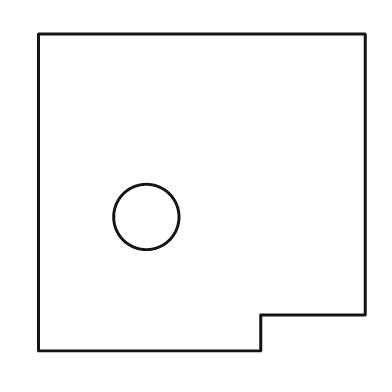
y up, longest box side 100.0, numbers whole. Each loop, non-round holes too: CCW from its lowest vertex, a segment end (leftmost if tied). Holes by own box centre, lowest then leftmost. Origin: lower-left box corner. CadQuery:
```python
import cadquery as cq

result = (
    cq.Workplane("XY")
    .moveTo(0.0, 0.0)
    .lineTo(68.0, 0.0)
    .lineTo(68.0, 11.0)
    .lineTo(100.0, 11.0)
    .lineTo(100.0, 97.0)
    .lineTo(0.0, 97.0)
    .close()
    .moveTo(33.0, 41.0)
    .circle(10.0)
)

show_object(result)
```